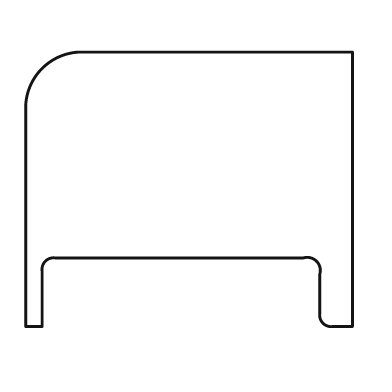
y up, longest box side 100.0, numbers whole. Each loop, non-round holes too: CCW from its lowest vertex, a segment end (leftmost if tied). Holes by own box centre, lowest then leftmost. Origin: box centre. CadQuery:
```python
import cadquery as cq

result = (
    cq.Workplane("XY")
    .moveTo(-50.0, -42.0)
    .lineTo(-45.0, -42.0)
    .lineTo(-45.0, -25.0)
    .threePointArc((-44.0, -22.0), (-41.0, -21.0))
    .lineTo(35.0, -21.0)
    .threePointArc((39.0, -22.0), (40.0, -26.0))
    .lineTo(40.0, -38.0)
    .threePointArc((41.0, -41.0), (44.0, -42.0))
    .lineTo(50.0, -42.0)
    .lineTo(50.0, 42.0)
    .lineTo(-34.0, 42.0)
    .threePointArc((-45.0, 37.0), (-50.0, 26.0))
    .close()
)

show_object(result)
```